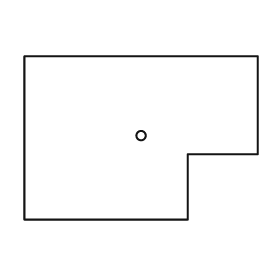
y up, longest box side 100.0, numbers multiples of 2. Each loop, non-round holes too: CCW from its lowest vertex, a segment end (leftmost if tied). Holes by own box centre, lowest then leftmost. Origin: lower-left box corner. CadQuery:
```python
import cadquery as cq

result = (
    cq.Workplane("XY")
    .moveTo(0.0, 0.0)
    .lineTo(70.0, 0.0)
    .lineTo(70.0, 28.0)
    .lineTo(100.0, 28.0)
    .lineTo(100.0, 70.0)
    .lineTo(0.0, 70.0)
    .close()
    .moveTo(50.0, 36.0)
    .circle(2.0)
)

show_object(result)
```